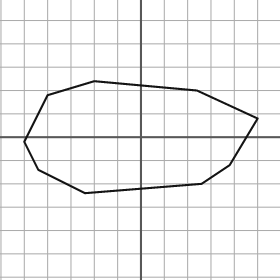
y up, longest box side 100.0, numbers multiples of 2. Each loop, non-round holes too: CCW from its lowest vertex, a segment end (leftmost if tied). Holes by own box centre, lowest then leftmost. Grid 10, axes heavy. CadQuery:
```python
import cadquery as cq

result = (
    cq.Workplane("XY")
    .moveTo(-24.0, -24.0)
    .lineTo(26.0, -20.0)
    .lineTo(38.0, -12.0)
    .lineTo(50.0, 8.0)
    .lineTo(24.0, 20.0)
    .lineTo(-20.0, 24.0)
    .lineTo(-40.0, 18.0)
    .lineTo(-50.0, -2.0)
    .lineTo(-44.0, -14.0)
    .close()
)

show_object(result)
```